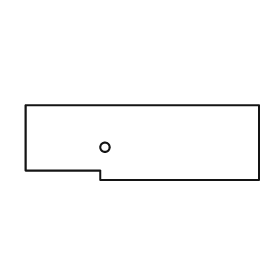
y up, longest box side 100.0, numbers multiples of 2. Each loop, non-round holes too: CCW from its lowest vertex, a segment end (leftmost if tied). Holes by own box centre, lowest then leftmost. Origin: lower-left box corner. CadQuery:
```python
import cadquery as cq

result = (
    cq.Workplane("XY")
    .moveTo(32.0, 0.0)
    .lineTo(100.0, 0.0)
    .lineTo(100.0, 32.0)
    .lineTo(0.0, 32.0)
    .lineTo(0.0, 4.0)
    .lineTo(32.0, 4.0)
    .close()
    .moveTo(34.0, 14.0)
    .circle(2.0)
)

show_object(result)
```